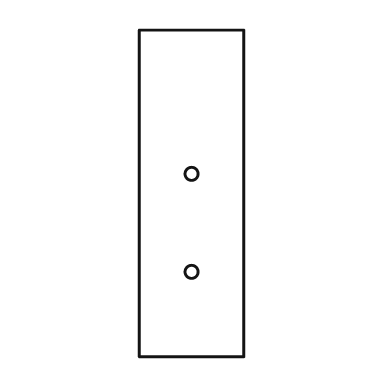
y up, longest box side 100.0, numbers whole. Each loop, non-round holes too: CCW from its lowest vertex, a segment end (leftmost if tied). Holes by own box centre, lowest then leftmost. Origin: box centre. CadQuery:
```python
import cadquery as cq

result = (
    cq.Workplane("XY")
    .moveTo(-16.0, -50.0)
    .lineTo(16.0, -50.0)
    .lineTo(16.0, 50.0)
    .lineTo(-16.0, 50.0)
    .close()
    .moveTo(0.0, -24.0)
    .circle(2.0)
    .moveTo(0.0, 6.0)
    .circle(2.0)
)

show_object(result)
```